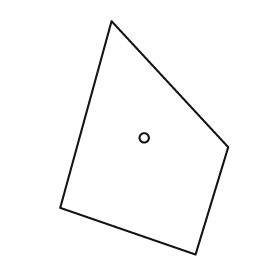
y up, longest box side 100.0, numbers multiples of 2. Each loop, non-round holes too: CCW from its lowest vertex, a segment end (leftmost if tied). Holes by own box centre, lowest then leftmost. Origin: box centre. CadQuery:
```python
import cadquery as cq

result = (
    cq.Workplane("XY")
    .moveTo(22.0, -50.0)
    .lineTo(36.0, -4.0)
    .lineTo(-14.0, 50.0)
    .lineTo(-36.0, -30.0)
    .close()
    .moveTo(0.0, 0.0)
    .circle(2.0)
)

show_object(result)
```